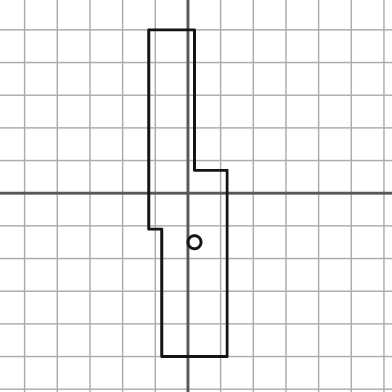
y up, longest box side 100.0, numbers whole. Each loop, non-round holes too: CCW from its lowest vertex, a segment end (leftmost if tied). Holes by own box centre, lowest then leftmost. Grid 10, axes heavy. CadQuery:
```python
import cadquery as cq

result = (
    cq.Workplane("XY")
    .moveTo(-8.0, -50.0)
    .lineTo(12.0, -50.0)
    .lineTo(12.0, 7.0)
    .lineTo(2.0, 7.0)
    .lineTo(2.0, 50.0)
    .lineTo(-12.0, 50.0)
    .lineTo(-12.0, -11.0)
    .lineTo(-8.0, -11.0)
    .close()
    .moveTo(2.0, -15.0)
    .circle(2.0)
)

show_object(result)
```